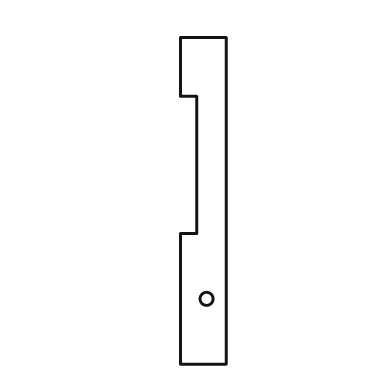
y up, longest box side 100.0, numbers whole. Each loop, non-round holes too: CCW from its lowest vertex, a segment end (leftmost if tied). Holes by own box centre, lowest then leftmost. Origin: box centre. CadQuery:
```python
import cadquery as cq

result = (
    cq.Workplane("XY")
    .moveTo(-7.0, -50.0)
    .lineTo(7.0, -50.0)
    .lineTo(7.0, 50.0)
    .lineTo(-7.0, 50.0)
    .lineTo(-7.0, 32.0)
    .lineTo(-2.0, 32.0)
    .lineTo(-2.0, -10.0)
    .lineTo(-7.0, -10.0)
    .close()
    .moveTo(1.0, -30.0)
    .circle(2.0)
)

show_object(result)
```